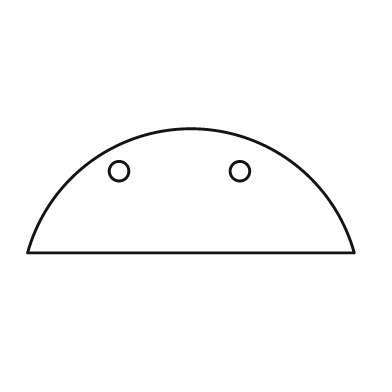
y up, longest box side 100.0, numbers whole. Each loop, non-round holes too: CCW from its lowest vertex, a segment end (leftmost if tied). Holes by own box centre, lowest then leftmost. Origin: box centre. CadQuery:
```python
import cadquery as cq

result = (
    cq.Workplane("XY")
    .moveTo(-50.0, -19.0)
    .lineTo(50.0, -19.0)
    .threePointArc((0.0, 19.0), (-50.0, -19.0))
    .close()
    .moveTo(-22.0, 6.0)
    .circle(3.0)
    .moveTo(15.0, 6.0)
    .circle(3.0)
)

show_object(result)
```